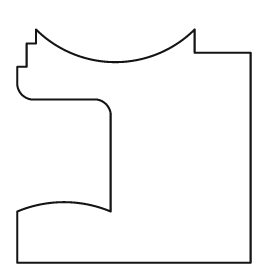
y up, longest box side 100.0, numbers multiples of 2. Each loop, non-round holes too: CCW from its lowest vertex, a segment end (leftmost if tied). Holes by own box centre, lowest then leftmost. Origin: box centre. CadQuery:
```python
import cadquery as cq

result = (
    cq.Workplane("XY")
    .moveTo(-50.0, -50.0)
    .lineTo(50.0, -50.0)
    .lineTo(50.0, 40.0)
    .lineTo(26.0, 40.0)
    .lineTo(26.0, 50.0)
    .threePointArc((-8.0, 36.0), (-42.0, 50.0))
    .lineTo(-42.0, 44.0)
    .lineTo(-46.0, 44.0)
    .lineTo(-46.0, 34.0)
    .lineTo(-50.0, 34.0)
    .lineTo(-50.0, 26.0)
    .threePointArc((-48.0, 22.0), (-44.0, 20.0))
    .lineTo(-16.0, 20.0)
    .threePointArc((-12.0, 18.0), (-10.0, 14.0))
    .lineTo(-10.0, -28.0)
    .threePointArc((-30.0, -24.0), (-50.0, -28.0))
    .close()
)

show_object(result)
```